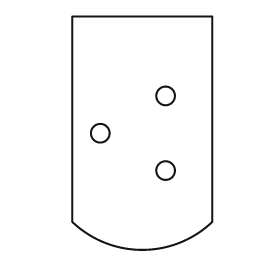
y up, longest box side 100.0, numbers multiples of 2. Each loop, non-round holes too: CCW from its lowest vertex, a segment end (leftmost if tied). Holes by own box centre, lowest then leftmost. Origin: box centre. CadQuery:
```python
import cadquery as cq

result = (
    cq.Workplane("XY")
    .moveTo(-30.0, -38.0)
    .threePointArc((0.0, -50.0), (30.0, -38.0))
    .lineTo(30.0, 50.0)
    .lineTo(-30.0, 50.0)
    .close()
    .moveTo(10.0, -16.0)
    .circle(4.0)
    .moveTo(-18.0, 0.0)
    .circle(4.0)
    .moveTo(10.0, 16.0)
    .circle(4.0)
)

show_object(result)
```